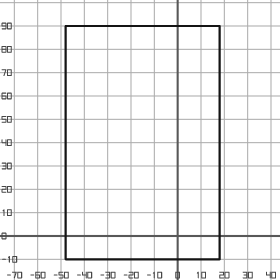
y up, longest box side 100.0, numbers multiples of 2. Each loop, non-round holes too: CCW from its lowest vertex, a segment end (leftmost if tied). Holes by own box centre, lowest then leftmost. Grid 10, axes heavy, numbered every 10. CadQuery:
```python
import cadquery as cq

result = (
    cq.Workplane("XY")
    .moveTo(-48.0, -10.0)
    .lineTo(18.0, -10.0)
    .lineTo(18.0, 90.0)
    .lineTo(-48.0, 90.0)
    .close()
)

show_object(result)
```